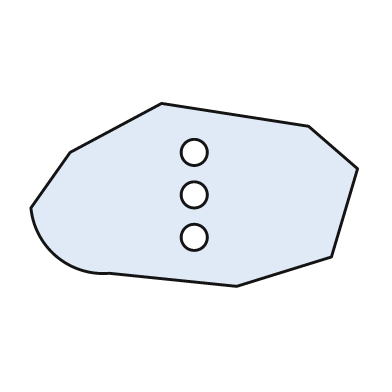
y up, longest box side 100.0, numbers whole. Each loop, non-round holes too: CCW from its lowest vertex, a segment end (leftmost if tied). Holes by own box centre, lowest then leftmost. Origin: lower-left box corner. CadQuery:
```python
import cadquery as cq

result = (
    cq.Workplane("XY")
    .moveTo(63.0, 0.0)
    .lineTo(92.0, 9.0)
    .lineTo(100.0, 36.0)
    .lineTo(85.0, 49.0)
    .lineTo(40.0, 56.0)
    .lineTo(12.0, 41.0)
    .lineTo(0.0, 24.0)
    .threePointArc((8.0, 9.0), (24.0, 4.0))
    .close()
    .moveTo(50.0, 15.0)
    .circle(4.0)
    .moveTo(50.0, 28.0)
    .circle(4.0)
    .moveTo(50.0, 41.0)
    .circle(4.0)
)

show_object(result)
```